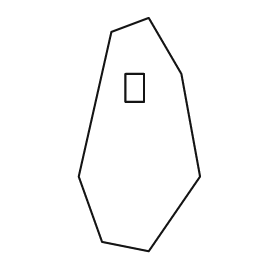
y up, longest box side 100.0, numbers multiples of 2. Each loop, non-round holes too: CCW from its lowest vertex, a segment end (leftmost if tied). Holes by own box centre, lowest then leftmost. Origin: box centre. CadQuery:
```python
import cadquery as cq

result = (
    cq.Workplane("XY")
    .moveTo(4.0, -50.0)
    .lineTo(26.0, -18.0)
    .lineTo(18.0, 26.0)
    .lineTo(4.0, 50.0)
    .lineTo(-12.0, 44.0)
    .lineTo(-26.0, -18.0)
    .lineTo(-16.0, -46.0)
    .close()
    .moveTo(-6.0, 14.0)
    .lineTo(2.0, 14.0)
    .lineTo(2.0, 26.0)
    .lineTo(-6.0, 26.0)
    .close()
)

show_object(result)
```